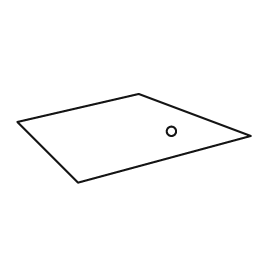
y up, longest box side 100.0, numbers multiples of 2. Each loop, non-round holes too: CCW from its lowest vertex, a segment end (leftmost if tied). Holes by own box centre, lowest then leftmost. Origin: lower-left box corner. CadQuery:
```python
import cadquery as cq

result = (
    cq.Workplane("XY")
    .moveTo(26.0, 0.0)
    .lineTo(100.0, 20.0)
    .lineTo(52.0, 38.0)
    .lineTo(0.0, 26.0)
    .close()
    .moveTo(66.0, 22.0)
    .circle(2.0)
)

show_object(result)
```